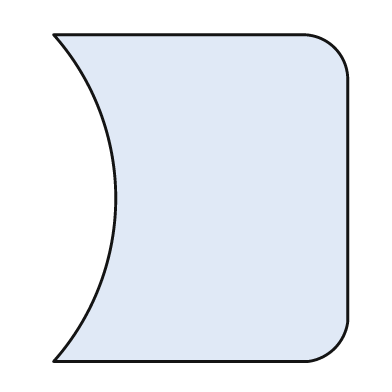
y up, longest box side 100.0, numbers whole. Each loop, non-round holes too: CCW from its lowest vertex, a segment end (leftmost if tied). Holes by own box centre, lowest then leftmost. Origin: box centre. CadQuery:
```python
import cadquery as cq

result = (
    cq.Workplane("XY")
    .moveTo(-45.0, -50.0)
    .lineTo(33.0, -50.0)
    .threePointArc((41.0, -46.0), (45.0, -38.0))
    .lineTo(45.0, 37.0)
    .threePointArc((41.0, 46.0), (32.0, 50.0))
    .lineTo(-45.0, 50.0)
    .threePointArc((-26.0, 0.0), (-45.0, -50.0))
    .close()
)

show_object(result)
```